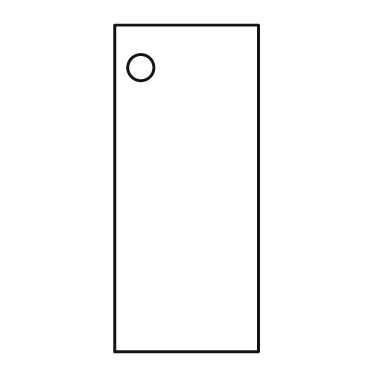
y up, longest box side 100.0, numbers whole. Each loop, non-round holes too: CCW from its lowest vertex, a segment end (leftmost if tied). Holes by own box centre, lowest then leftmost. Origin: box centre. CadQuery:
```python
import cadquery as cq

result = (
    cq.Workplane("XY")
    .moveTo(-22.0, -50.0)
    .lineTo(22.0, -50.0)
    .lineTo(22.0, 50.0)
    .lineTo(-22.0, 50.0)
    .close()
    .moveTo(-14.0, 37.0)
    .circle(4.0)
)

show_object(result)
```